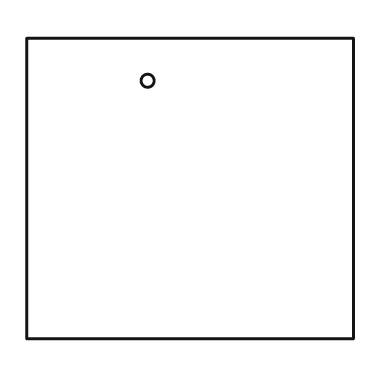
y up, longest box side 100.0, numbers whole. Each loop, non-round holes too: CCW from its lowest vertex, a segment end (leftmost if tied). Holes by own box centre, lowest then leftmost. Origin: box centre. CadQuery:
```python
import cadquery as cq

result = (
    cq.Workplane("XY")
    .moveTo(-50.0, -46.0)
    .lineTo(50.0, -46.0)
    .lineTo(50.0, 46.0)
    .lineTo(-50.0, 46.0)
    .close()
    .moveTo(-13.0, 33.0)
    .circle(2.0)
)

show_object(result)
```